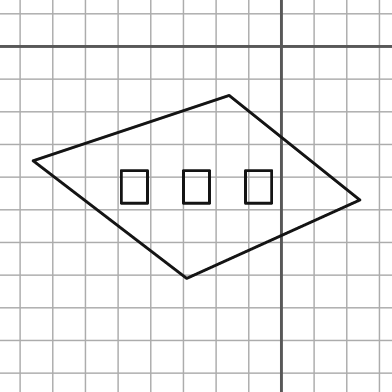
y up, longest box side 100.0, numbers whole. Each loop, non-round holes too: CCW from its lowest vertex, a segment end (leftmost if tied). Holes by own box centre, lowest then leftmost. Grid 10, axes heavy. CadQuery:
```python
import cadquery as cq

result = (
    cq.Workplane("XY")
    .moveTo(-29.0, -71.0)
    .lineTo(24.0, -47.0)
    .lineTo(-16.0, -15.0)
    .lineTo(-76.0, -35.0)
    .close()
    .moveTo(-49.0, -48.0)
    .lineTo(-41.0, -48.0)
    .lineTo(-41.0, -38.0)
    .lineTo(-49.0, -38.0)
    .close()
    .moveTo(-30.0, -48.0)
    .lineTo(-22.0, -48.0)
    .lineTo(-22.0, -38.0)
    .lineTo(-30.0, -38.0)
    .close()
    .moveTo(-11.0, -48.0)
    .lineTo(-3.0, -48.0)
    .lineTo(-3.0, -38.0)
    .lineTo(-11.0, -38.0)
    .close()
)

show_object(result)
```